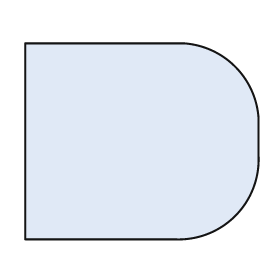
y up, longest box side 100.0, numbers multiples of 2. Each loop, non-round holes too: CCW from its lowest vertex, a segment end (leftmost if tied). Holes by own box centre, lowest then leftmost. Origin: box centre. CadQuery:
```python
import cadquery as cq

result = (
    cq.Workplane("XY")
    .moveTo(-50.0, -42.0)
    .lineTo(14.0, -42.0)
    .threePointArc((40.0, -32.0), (50.0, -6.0))
    .lineTo(50.0, 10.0)
    .threePointArc((40.0, 32.0), (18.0, 42.0))
    .lineTo(-50.0, 42.0)
    .close()
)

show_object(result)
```